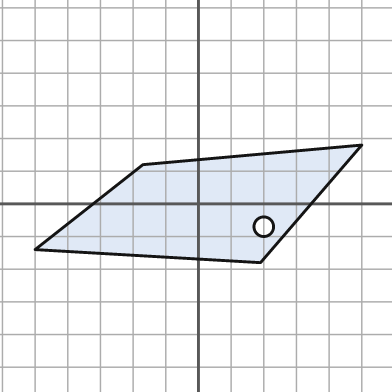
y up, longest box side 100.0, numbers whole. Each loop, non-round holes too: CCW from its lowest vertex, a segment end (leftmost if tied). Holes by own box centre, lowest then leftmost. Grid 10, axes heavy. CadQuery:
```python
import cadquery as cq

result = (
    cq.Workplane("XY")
    .moveTo(19.0, -18.0)
    .lineTo(50.0, 18.0)
    .lineTo(-17.0, 12.0)
    .lineTo(-50.0, -14.0)
    .close()
    .moveTo(20.0, -7.0)
    .circle(3.0)
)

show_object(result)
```